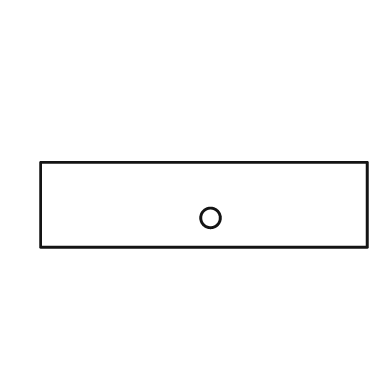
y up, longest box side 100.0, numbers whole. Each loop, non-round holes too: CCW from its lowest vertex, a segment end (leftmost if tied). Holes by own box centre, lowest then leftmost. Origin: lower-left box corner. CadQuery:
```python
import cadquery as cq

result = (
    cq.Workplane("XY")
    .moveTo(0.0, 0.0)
    .lineTo(100.0, 0.0)
    .lineTo(100.0, 26.0)
    .lineTo(0.0, 26.0)
    .close()
    .moveTo(52.0, 9.0)
    .circle(3.0)
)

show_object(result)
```